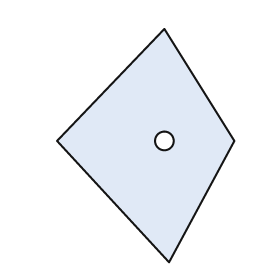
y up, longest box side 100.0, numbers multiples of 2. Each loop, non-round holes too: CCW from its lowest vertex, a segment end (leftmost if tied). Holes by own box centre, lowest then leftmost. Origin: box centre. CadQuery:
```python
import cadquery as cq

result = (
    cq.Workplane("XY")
    .moveTo(10.0, -50.0)
    .lineTo(38.0, 2.0)
    .lineTo(8.0, 50.0)
    .lineTo(-38.0, 2.0)
    .close()
    .moveTo(8.0, 2.0)
    .circle(4.0)
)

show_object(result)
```